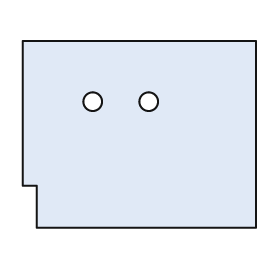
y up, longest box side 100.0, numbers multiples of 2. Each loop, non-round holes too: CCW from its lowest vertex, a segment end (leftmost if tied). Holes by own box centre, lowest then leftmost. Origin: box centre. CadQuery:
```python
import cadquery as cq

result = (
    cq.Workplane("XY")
    .moveTo(-44.0, -40.0)
    .lineTo(50.0, -40.0)
    .lineTo(50.0, 40.0)
    .lineTo(-50.0, 40.0)
    .lineTo(-50.0, -22.0)
    .lineTo(-44.0, -22.0)
    .close()
    .moveTo(-20.0, 14.0)
    .circle(4.0)
    .moveTo(4.0, 14.0)
    .circle(4.0)
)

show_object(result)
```